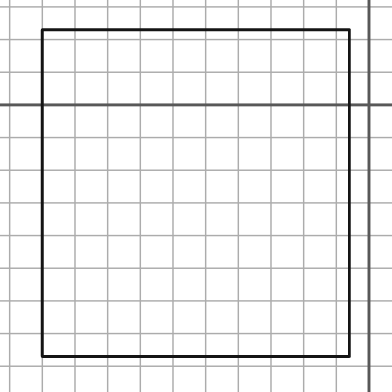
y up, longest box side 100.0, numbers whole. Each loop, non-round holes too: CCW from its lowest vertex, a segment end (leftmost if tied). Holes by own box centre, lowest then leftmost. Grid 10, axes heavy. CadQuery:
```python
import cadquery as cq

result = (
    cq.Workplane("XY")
    .moveTo(-100.0, -77.0)
    .lineTo(-6.0, -77.0)
    .lineTo(-6.0, 23.0)
    .lineTo(-100.0, 23.0)
    .close()
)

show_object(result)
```